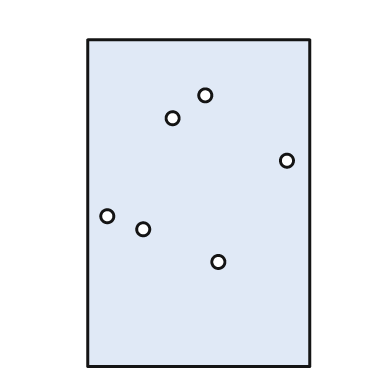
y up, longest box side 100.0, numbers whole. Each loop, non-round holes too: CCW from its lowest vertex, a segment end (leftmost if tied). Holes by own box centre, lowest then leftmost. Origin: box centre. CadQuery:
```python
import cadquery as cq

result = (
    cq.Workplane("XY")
    .moveTo(-34.0, -50.0)
    .lineTo(34.0, -50.0)
    .lineTo(34.0, 50.0)
    .lineTo(-34.0, 50.0)
    .close()
    .moveTo(6.0, -18.0)
    .circle(2.0)
    .moveTo(-17.0, -8.0)
    .circle(2.0)
    .moveTo(-28.0, -4.0)
    .circle(2.0)
    .moveTo(27.0, 13.0)
    .circle(2.0)
    .moveTo(-8.0, 26.0)
    .circle(2.0)
    .moveTo(2.0, 33.0)
    .circle(2.0)
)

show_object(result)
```